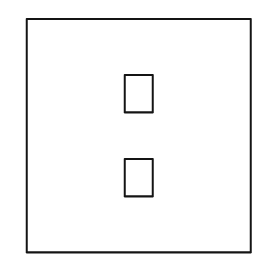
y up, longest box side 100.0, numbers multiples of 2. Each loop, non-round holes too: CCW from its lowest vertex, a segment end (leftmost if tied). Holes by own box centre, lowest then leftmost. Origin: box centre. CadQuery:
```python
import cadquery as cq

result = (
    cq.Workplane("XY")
    .moveTo(-48.0, -50.0)
    .lineTo(48.0, -50.0)
    .lineTo(48.0, 50.0)
    .lineTo(-48.0, 50.0)
    .close()
    .moveTo(-6.0, -26.0)
    .lineTo(6.0, -26.0)
    .lineTo(6.0, -10.0)
    .lineTo(-6.0, -10.0)
    .close()
    .moveTo(-6.0, 10.0)
    .lineTo(6.0, 10.0)
    .lineTo(6.0, 26.0)
    .lineTo(-6.0, 26.0)
    .close()
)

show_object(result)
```